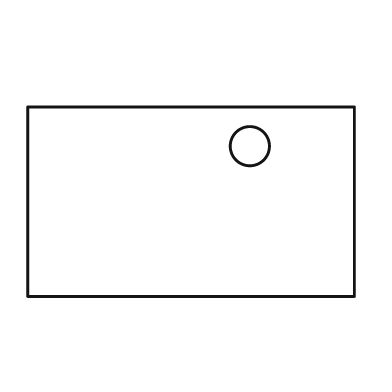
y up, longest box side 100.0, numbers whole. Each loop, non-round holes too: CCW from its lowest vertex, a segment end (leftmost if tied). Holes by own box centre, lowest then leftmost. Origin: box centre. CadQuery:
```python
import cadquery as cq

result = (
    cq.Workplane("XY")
    .moveTo(-50.0, -29.0)
    .lineTo(50.0, -29.0)
    .lineTo(50.0, 29.0)
    .lineTo(-50.0, 29.0)
    .close()
    .moveTo(18.0, 17.0)
    .circle(6.0)
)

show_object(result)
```